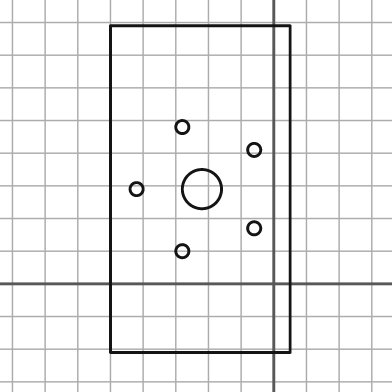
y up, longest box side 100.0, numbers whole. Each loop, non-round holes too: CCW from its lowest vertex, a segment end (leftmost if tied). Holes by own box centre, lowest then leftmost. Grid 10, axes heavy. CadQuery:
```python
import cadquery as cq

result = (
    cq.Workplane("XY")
    .moveTo(-50.0, -21.0)
    .lineTo(5.0, -21.0)
    .lineTo(5.0, 79.0)
    .lineTo(-50.0, 79.0)
    .close()
    .moveTo(-28.0, 10.0)
    .circle(2.0)
    .moveTo(-6.0, 17.0)
    .circle(2.0)
    .moveTo(-42.0, 29.0)
    .circle(2.0)
    .moveTo(-22.0, 29.0)
    .circle(6.0)
    .moveTo(-6.0, 41.0)
    .circle(2.0)
    .moveTo(-28.0, 48.0)
    .circle(2.0)
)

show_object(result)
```